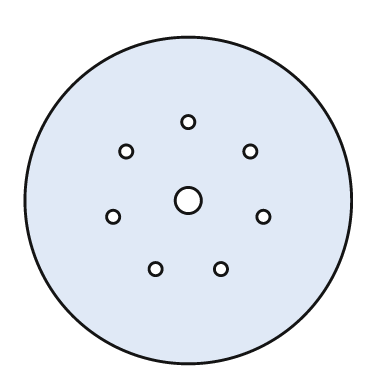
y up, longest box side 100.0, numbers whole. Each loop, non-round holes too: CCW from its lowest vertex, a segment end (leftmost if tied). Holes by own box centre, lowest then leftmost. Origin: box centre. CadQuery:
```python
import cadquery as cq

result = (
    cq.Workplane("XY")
    .moveTo(0.0, 0.0)
    .circle(50.0)
    .moveTo(-10.0, -21.0)
    .circle(2.0)
    .moveTo(10.0, -21.0)
    .circle(2.0)
    .moveTo(-23.0, -5.0)
    .circle(2.0)
    .moveTo(23.0, -5.0)
    .circle(2.0)
    .moveTo(0.0, 0.0)
    .circle(4.0)
    .moveTo(-19.0, 15.0)
    .circle(2.0)
    .moveTo(19.0, 15.0)
    .circle(2.0)
    .moveTo(0.0, 24.0)
    .circle(2.0)
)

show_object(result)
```